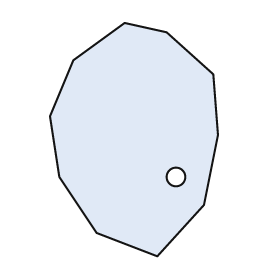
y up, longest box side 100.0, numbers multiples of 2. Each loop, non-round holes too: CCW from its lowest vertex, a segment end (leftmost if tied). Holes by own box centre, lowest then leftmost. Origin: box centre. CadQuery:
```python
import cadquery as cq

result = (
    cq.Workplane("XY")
    .moveTo(10.0, -50.0)
    .lineTo(30.0, -28.0)
    .lineTo(36.0, 2.0)
    .lineTo(34.0, 28.0)
    .lineTo(14.0, 46.0)
    .lineTo(-4.0, 50.0)
    .lineTo(-26.0, 34.0)
    .lineTo(-36.0, 10.0)
    .lineTo(-32.0, -16.0)
    .lineTo(-16.0, -40.0)
    .close()
    .moveTo(18.0, -16.0)
    .circle(4.0)
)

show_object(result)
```